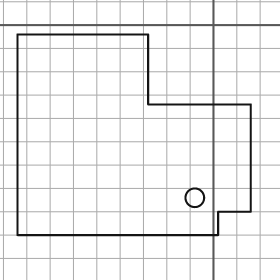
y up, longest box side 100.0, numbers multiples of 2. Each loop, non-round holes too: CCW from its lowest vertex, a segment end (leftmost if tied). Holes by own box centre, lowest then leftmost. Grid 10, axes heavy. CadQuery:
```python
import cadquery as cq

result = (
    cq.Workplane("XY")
    .moveTo(-84.0, -90.0)
    .lineTo(2.0, -90.0)
    .lineTo(2.0, -80.0)
    .lineTo(16.0, -80.0)
    .lineTo(16.0, -34.0)
    .lineTo(-28.0, -34.0)
    .lineTo(-28.0, -4.0)
    .lineTo(-84.0, -4.0)
    .close()
    .moveTo(-8.0, -74.0)
    .circle(4.0)
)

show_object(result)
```